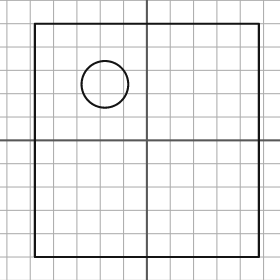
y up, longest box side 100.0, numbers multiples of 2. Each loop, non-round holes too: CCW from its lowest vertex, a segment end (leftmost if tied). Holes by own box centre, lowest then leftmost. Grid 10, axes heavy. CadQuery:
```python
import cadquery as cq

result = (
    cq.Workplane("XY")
    .moveTo(-48.0, -50.0)
    .lineTo(48.0, -50.0)
    .lineTo(48.0, 50.0)
    .lineTo(-48.0, 50.0)
    .close()
    .moveTo(-18.0, 24.0)
    .circle(10.0)
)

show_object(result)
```